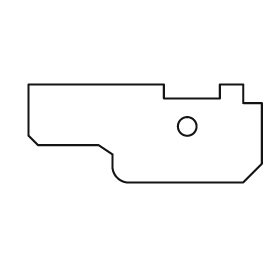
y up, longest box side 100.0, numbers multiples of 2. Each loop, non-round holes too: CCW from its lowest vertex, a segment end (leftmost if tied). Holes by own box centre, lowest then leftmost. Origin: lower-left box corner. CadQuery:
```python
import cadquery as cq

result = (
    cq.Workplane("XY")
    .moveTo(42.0, 0.0)
    .lineTo(92.0, 0.0)
    .lineTo(100.0, 8.0)
    .lineTo(100.0, 34.0)
    .lineTo(92.0, 34.0)
    .lineTo(92.0, 42.0)
    .lineTo(82.0, 42.0)
    .lineTo(82.0, 36.0)
    .lineTo(58.0, 36.0)
    .lineTo(58.0, 42.0)
    .lineTo(0.0, 42.0)
    .lineTo(0.0, 20.0)
    .lineTo(4.0, 16.0)
    .lineTo(30.0, 16.0)
    .lineTo(36.0, 12.0)
    .lineTo(36.0, 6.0)
    .threePointArc((38.0, 2.0), (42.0, 0.0))
    .close()
    .moveTo(68.0, 24.0)
    .circle(4.0)
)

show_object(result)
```